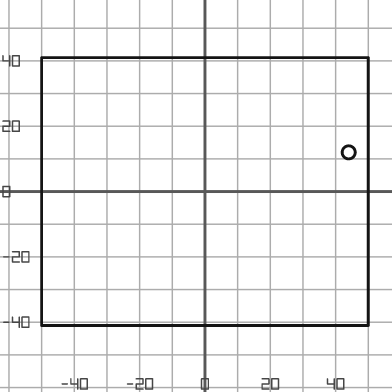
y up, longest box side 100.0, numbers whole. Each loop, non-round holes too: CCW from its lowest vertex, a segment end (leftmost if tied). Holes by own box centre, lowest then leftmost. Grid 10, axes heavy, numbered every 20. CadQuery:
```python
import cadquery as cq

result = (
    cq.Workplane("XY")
    .moveTo(-50.0, -41.0)
    .lineTo(50.0, -41.0)
    .lineTo(50.0, 41.0)
    .lineTo(-50.0, 41.0)
    .close()
    .moveTo(44.0, 12.0)
    .circle(2.0)
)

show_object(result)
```